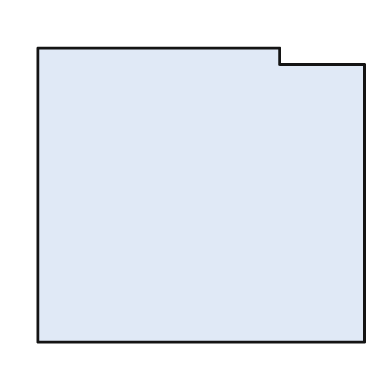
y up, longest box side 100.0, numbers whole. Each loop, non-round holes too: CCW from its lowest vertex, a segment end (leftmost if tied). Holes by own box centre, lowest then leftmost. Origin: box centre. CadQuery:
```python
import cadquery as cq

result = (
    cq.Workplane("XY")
    .moveTo(-50.0, -45.0)
    .lineTo(50.0, -45.0)
    .lineTo(50.0, 40.0)
    .lineTo(24.0, 40.0)
    .lineTo(24.0, 45.0)
    .lineTo(-50.0, 45.0)
    .close()
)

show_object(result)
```